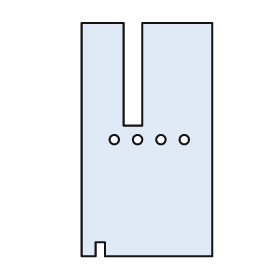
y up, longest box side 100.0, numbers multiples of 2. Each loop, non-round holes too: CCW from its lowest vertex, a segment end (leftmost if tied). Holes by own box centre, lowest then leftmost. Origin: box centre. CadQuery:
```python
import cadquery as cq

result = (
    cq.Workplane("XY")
    .moveTo(-28.0, -50.0)
    .lineTo(-22.0, -50.0)
    .lineTo(-22.0, -44.0)
    .lineTo(-18.0, -44.0)
    .lineTo(-18.0, -50.0)
    .lineTo(28.0, -50.0)
    .lineTo(28.0, 50.0)
    .lineTo(-2.0, 50.0)
    .lineTo(-2.0, 6.0)
    .lineTo(-10.0, 6.0)
    .lineTo(-10.0, 50.0)
    .lineTo(-28.0, 50.0)
    .close()
    .moveTo(-14.0, 0.0)
    .circle(2.0)
    .moveTo(-4.0, 0.0)
    .circle(2.0)
    .moveTo(6.0, 0.0)
    .circle(2.0)
    .moveTo(16.0, 0.0)
    .circle(2.0)
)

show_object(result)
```